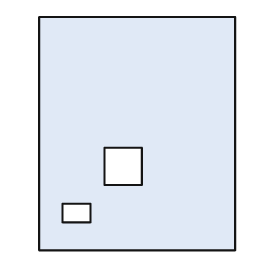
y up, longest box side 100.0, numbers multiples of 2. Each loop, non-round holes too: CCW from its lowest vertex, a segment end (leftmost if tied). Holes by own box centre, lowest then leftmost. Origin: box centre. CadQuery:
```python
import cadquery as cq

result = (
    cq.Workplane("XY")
    .moveTo(-42.0, -50.0)
    .lineTo(42.0, -50.0)
    .lineTo(42.0, 50.0)
    .lineTo(-42.0, 50.0)
    .close()
    .moveTo(-32.0, -38.0)
    .lineTo(-20.0, -38.0)
    .lineTo(-20.0, -30.0)
    .lineTo(-32.0, -30.0)
    .close()
    .moveTo(-14.0, -22.0)
    .lineTo(2.0, -22.0)
    .lineTo(2.0, -6.0)
    .lineTo(-14.0, -6.0)
    .close()
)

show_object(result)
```